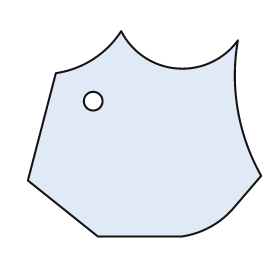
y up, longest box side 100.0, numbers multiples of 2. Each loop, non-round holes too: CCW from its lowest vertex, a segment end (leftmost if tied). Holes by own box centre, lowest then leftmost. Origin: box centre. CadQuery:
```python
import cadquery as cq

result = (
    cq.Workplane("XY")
    .moveTo(-20.0, -44.0)
    .lineTo(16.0, -44.0)
    .threePointArc((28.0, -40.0), (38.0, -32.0))
    .lineTo(50.0, -18.0)
    .threePointArc((40.0, 10.0), (40.0, 40.0))
    .threePointArc((14.0, 28.0), (-10.0, 44.0))
    .threePointArc((-22.0, 32.0), (-38.0, 26.0))
    .lineTo(-50.0, -20.0)
    .close()
    .moveTo(-22.0, 14.0)
    .circle(4.0)
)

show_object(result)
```